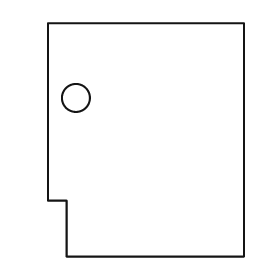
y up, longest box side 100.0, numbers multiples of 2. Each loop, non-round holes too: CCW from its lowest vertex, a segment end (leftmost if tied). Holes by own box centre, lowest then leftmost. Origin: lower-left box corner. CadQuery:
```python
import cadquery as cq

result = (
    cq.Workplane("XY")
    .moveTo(8.0, 0.0)
    .lineTo(84.0, 0.0)
    .lineTo(84.0, 100.0)
    .lineTo(0.0, 100.0)
    .lineTo(0.0, 24.0)
    .lineTo(8.0, 24.0)
    .close()
    .moveTo(12.0, 68.0)
    .circle(6.0)
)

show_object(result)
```